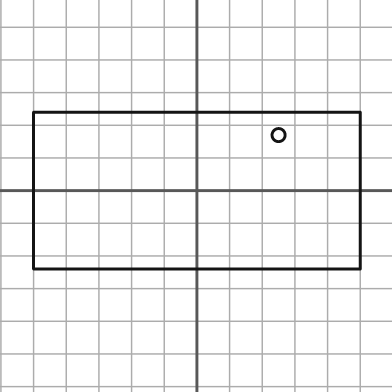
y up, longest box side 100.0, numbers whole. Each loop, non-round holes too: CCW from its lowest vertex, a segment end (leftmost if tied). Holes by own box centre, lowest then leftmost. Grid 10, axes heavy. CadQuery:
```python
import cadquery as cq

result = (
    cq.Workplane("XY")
    .moveTo(-50.0, -24.0)
    .lineTo(50.0, -24.0)
    .lineTo(50.0, 24.0)
    .lineTo(-50.0, 24.0)
    .close()
    .moveTo(25.0, 17.0)
    .circle(2.0)
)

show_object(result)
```